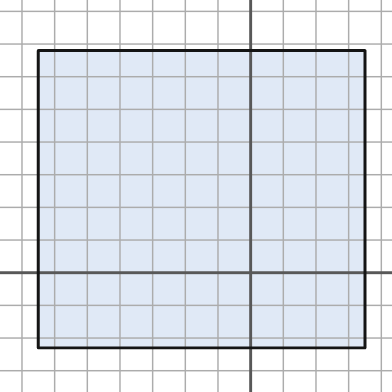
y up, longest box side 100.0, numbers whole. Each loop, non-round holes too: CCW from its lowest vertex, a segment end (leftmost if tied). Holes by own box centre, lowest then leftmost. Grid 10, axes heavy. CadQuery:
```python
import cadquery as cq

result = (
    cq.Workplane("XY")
    .moveTo(-65.0, -23.0)
    .lineTo(35.0, -23.0)
    .lineTo(35.0, 68.0)
    .lineTo(-65.0, 68.0)
    .close()
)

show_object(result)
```